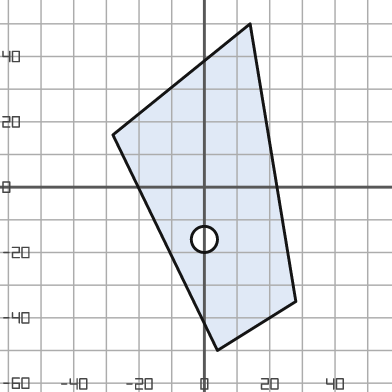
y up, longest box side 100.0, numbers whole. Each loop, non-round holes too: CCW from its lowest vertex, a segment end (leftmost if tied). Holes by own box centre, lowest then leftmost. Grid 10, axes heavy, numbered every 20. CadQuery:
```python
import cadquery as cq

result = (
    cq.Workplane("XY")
    .moveTo(4.0, -50.0)
    .lineTo(28.0, -35.0)
    .lineTo(14.0, 50.0)
    .lineTo(-28.0, 16.0)
    .close()
    .moveTo(0.0, -16.0)
    .circle(4.0)
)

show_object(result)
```